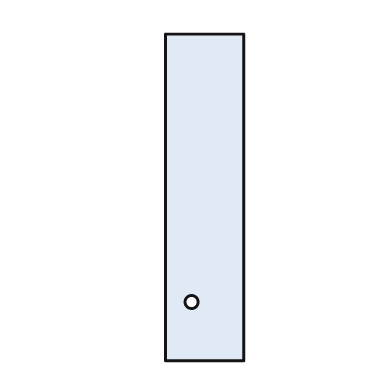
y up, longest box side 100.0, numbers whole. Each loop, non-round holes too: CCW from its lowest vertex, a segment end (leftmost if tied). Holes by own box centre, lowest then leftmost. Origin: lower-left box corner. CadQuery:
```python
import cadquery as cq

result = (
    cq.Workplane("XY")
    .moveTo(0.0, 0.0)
    .lineTo(24.0, 0.0)
    .lineTo(24.0, 100.0)
    .lineTo(0.0, 100.0)
    .close()
    .moveTo(8.0, 18.0)
    .circle(2.0)
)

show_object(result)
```